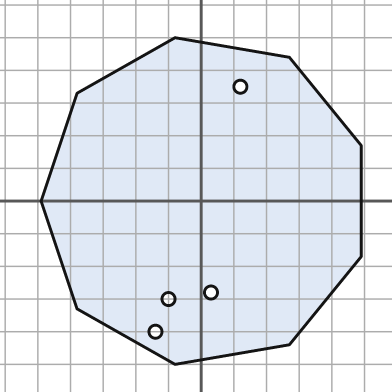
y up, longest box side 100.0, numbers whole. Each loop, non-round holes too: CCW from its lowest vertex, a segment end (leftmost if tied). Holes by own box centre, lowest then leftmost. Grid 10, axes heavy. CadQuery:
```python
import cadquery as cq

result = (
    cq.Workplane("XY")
    .moveTo(-8.0, -50.0)
    .lineTo(27.0, -44.0)
    .lineTo(49.0, -17.0)
    .lineTo(49.0, 17.0)
    .lineTo(27.0, 44.0)
    .lineTo(-8.0, 50.0)
    .lineTo(-38.0, 33.0)
    .lineTo(-49.0, 0.0)
    .lineTo(-38.0, -33.0)
    .close()
    .moveTo(-14.0, -40.0)
    .circle(2.0)
    .moveTo(-10.0, -30.0)
    .circle(2.0)
    .moveTo(3.0, -28.0)
    .circle(2.0)
    .moveTo(12.0, 35.0)
    .circle(2.0)
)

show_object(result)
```